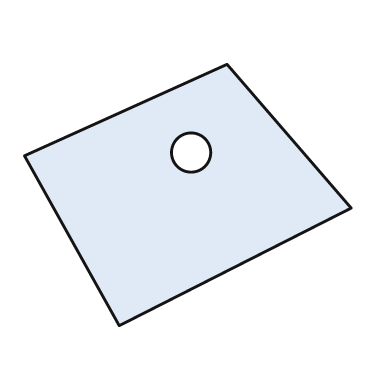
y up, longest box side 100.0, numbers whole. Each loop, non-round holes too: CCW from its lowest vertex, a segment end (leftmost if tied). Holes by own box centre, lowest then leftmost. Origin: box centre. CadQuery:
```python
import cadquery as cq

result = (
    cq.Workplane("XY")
    .moveTo(-21.0, -40.0)
    .lineTo(50.0, -4.0)
    .lineTo(12.0, 40.0)
    .lineTo(-50.0, 12.0)
    .close()
    .moveTo(1.0, 13.0)
    .circle(6.0)
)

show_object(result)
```